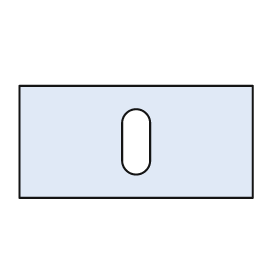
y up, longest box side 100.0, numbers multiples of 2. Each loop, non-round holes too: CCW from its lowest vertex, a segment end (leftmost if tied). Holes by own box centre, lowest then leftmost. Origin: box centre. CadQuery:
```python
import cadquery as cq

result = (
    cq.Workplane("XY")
    .moveTo(-50.0, -24.0)
    .lineTo(50.0, -24.0)
    .lineTo(50.0, 24.0)
    .lineTo(-50.0, 24.0)
    .close()
    .moveTo(-6.0, -8.0)
    .threePointArc((0.0, -14.0), (6.0, -8.0))
    .lineTo(6.0, 8.0)
    .threePointArc((0.0, 14.0), (-6.0, 8.0))
    .close()
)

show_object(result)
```